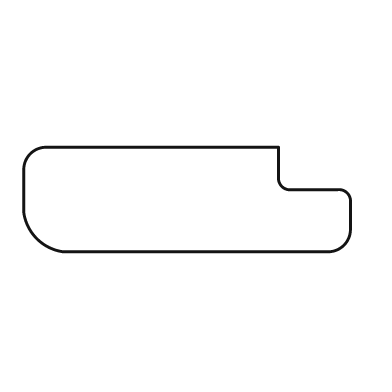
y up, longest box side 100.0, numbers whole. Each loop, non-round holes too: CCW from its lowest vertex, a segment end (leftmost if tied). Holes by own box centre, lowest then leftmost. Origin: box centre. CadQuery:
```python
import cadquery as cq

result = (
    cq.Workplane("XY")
    .moveTo(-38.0, -16.0)
    .lineTo(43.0, -16.0)
    .threePointArc((48.0, -14.0), (50.0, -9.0))
    .lineTo(50.0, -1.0)
    .threePointArc((49.0, 2.0), (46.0, 3.0))
    .lineTo(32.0, 3.0)
    .threePointArc((29.0, 4.0), (28.0, 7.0))
    .lineTo(28.0, 16.0)
    .lineTo(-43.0, 16.0)
    .threePointArc((-48.0, 14.0), (-50.0, 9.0))
    .lineTo(-50.0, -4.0)
    .threePointArc((-46.0, -12.0), (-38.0, -16.0))
    .close()
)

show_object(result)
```